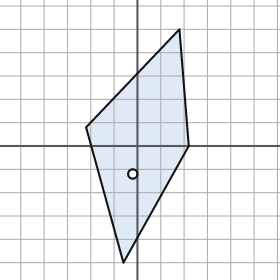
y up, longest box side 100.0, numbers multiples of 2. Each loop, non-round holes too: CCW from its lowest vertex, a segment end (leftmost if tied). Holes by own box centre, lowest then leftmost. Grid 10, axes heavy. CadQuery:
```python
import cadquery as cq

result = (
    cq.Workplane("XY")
    .moveTo(-6.0, -50.0)
    .lineTo(22.0, 0.0)
    .lineTo(18.0, 50.0)
    .lineTo(-22.0, 8.0)
    .close()
    .moveTo(-2.0, -12.0)
    .circle(2.0)
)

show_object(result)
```